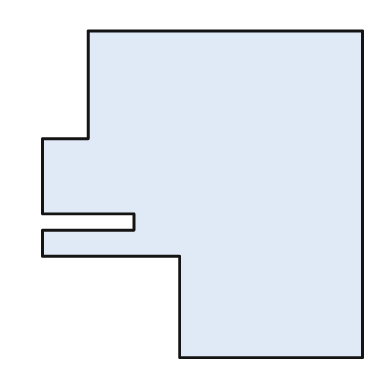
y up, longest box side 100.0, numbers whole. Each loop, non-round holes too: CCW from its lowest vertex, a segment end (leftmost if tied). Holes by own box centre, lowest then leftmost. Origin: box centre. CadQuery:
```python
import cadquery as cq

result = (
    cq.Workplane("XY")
    .moveTo(-7.0, -50.0)
    .lineTo(49.0, -50.0)
    .lineTo(49.0, 50.0)
    .lineTo(-35.0, 50.0)
    .lineTo(-35.0, 17.0)
    .lineTo(-49.0, 17.0)
    .lineTo(-49.0, -6.0)
    .lineTo(-21.0, -6.0)
    .lineTo(-21.0, -11.0)
    .lineTo(-49.0, -11.0)
    .lineTo(-49.0, -19.0)
    .lineTo(-7.0, -19.0)
    .close()
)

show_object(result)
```